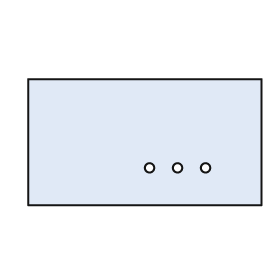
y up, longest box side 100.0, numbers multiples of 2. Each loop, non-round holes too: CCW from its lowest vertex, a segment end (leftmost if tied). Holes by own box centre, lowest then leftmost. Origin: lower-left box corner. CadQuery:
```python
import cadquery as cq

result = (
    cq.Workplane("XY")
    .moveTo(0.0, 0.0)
    .lineTo(100.0, 0.0)
    .lineTo(100.0, 54.0)
    .lineTo(0.0, 54.0)
    .close()
    .moveTo(52.0, 16.0)
    .circle(2.0)
    .moveTo(64.0, 16.0)
    .circle(2.0)
    .moveTo(76.0, 16.0)
    .circle(2.0)
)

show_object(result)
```